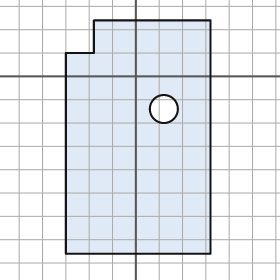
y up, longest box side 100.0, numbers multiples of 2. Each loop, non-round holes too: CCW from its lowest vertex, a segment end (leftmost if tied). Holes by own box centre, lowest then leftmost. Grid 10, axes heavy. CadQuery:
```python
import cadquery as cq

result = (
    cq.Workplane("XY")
    .moveTo(-30.0, -76.0)
    .lineTo(32.0, -76.0)
    .lineTo(32.0, 24.0)
    .lineTo(-18.0, 24.0)
    .lineTo(-18.0, 10.0)
    .lineTo(-30.0, 10.0)
    .close()
    .moveTo(12.0, -14.0)
    .circle(6.0)
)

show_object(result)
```